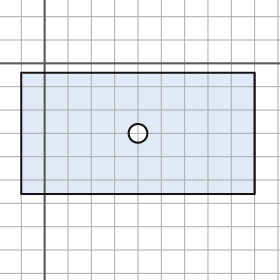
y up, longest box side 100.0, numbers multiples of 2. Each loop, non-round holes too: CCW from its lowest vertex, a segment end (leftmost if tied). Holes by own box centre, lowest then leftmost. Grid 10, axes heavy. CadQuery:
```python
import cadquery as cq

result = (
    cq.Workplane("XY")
    .moveTo(-10.0, -56.0)
    .lineTo(90.0, -56.0)
    .lineTo(90.0, -4.0)
    .lineTo(-10.0, -4.0)
    .close()
    .moveTo(40.0, -30.0)
    .circle(4.0)
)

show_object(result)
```